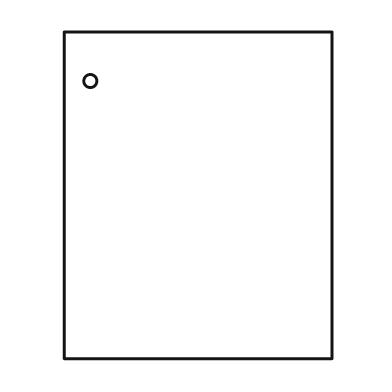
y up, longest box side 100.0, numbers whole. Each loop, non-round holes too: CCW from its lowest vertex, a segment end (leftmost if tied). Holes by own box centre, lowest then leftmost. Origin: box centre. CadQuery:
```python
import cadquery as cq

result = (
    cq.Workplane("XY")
    .moveTo(-41.0, -50.0)
    .lineTo(41.0, -50.0)
    .lineTo(41.0, 50.0)
    .lineTo(-41.0, 50.0)
    .close()
    .moveTo(-33.0, 35.0)
    .circle(2.0)
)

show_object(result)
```